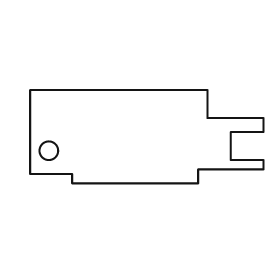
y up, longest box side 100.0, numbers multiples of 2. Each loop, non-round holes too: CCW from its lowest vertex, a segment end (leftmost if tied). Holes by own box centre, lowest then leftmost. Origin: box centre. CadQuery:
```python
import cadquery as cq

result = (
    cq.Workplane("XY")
    .moveTo(-32.0, -20.0)
    .lineTo(22.0, -20.0)
    .lineTo(22.0, -14.0)
    .lineTo(50.0, -14.0)
    .lineTo(50.0, -10.0)
    .lineTo(36.0, -10.0)
    .lineTo(36.0, 2.0)
    .lineTo(50.0, 2.0)
    .lineTo(50.0, 8.0)
    .lineTo(26.0, 8.0)
    .lineTo(26.0, 20.0)
    .lineTo(-50.0, 20.0)
    .lineTo(-50.0, -16.0)
    .lineTo(-32.0, -16.0)
    .close()
    .moveTo(-42.0, -6.0)
    .circle(4.0)
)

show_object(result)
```